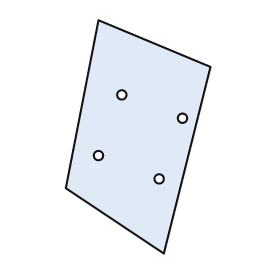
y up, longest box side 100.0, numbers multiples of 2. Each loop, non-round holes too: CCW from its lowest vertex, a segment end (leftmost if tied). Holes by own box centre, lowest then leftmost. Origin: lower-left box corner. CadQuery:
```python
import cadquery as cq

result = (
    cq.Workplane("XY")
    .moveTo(42.0, 0.0)
    .lineTo(62.0, 80.0)
    .lineTo(14.0, 100.0)
    .lineTo(0.0, 28.0)
    .close()
    .moveTo(40.0, 32.0)
    .circle(2.0)
    .moveTo(14.0, 42.0)
    .circle(2.0)
    .moveTo(50.0, 58.0)
    .circle(2.0)
    .moveTo(24.0, 68.0)
    .circle(2.0)
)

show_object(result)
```